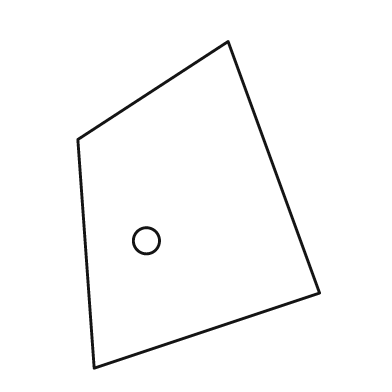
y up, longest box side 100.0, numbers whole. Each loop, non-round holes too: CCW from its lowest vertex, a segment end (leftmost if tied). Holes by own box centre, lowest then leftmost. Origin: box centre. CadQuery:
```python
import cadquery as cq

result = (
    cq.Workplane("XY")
    .moveTo(-32.0, -50.0)
    .lineTo(37.0, -27.0)
    .lineTo(9.0, 50.0)
    .lineTo(-37.0, 20.0)
    .close()
    .moveTo(-16.0, -11.0)
    .circle(4.0)
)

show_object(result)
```